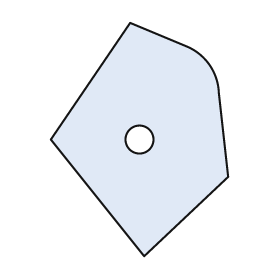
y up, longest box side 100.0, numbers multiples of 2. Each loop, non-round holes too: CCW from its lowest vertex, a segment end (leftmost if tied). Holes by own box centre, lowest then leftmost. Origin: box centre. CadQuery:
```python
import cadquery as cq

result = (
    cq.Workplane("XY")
    .moveTo(2.0, -50.0)
    .lineTo(38.0, -16.0)
    .lineTo(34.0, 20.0)
    .threePointArc((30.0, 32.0), (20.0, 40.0))
    .lineTo(-4.0, 50.0)
    .lineTo(-38.0, 0.0)
    .close()
    .moveTo(0.0, 0.0)
    .circle(6.0)
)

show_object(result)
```